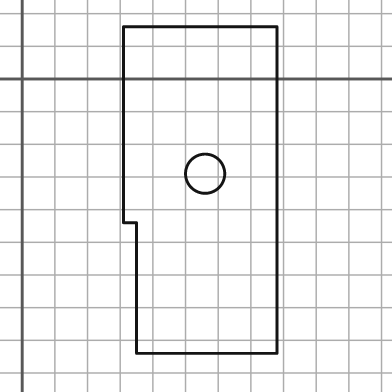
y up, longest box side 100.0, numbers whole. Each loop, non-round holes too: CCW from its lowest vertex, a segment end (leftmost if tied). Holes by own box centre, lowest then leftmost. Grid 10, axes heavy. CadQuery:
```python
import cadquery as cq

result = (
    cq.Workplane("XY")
    .moveTo(35.0, -84.0)
    .lineTo(78.0, -84.0)
    .lineTo(78.0, 16.0)
    .lineTo(31.0, 16.0)
    .lineTo(31.0, -44.0)
    .lineTo(35.0, -44.0)
    .close()
    .moveTo(56.0, -29.0)
    .circle(6.0)
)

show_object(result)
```